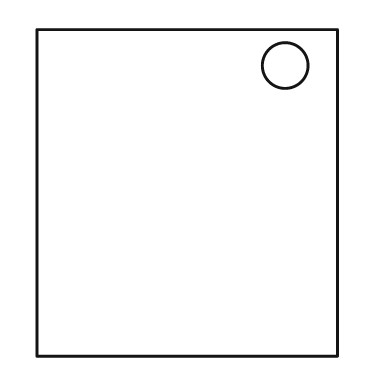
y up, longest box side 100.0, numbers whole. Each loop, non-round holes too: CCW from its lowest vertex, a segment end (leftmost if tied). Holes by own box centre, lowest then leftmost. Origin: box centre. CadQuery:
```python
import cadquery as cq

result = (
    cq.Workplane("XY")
    .moveTo(-46.0, -50.0)
    .lineTo(46.0, -50.0)
    .lineTo(46.0, 50.0)
    .lineTo(-46.0, 50.0)
    .close()
    .moveTo(30.0, 39.0)
    .circle(7.0)
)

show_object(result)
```